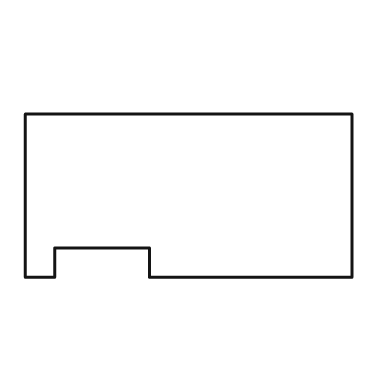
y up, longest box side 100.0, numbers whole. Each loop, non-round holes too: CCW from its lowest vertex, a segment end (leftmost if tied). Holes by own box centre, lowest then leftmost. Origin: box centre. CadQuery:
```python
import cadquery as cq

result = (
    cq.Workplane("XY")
    .moveTo(-50.0, -25.0)
    .lineTo(-41.0, -25.0)
    .lineTo(-41.0, -16.0)
    .lineTo(-12.0, -16.0)
    .lineTo(-12.0, -25.0)
    .lineTo(50.0, -25.0)
    .lineTo(50.0, 25.0)
    .lineTo(-50.0, 25.0)
    .close()
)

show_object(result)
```